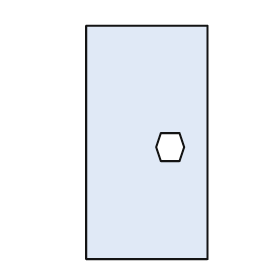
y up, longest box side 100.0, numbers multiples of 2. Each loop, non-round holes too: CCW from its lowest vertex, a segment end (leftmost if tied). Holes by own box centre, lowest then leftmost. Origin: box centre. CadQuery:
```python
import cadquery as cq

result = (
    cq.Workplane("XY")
    .moveTo(-26.0, -50.0)
    .lineTo(26.0, -50.0)
    .lineTo(26.0, 50.0)
    .lineTo(-26.0, 50.0)
    .close()
    .moveTo(6.0, -8.0)
    .lineTo(14.0, -8.0)
    .lineTo(16.0, -2.0)
    .lineTo(14.0, 4.0)
    .lineTo(6.0, 4.0)
    .lineTo(4.0, -2.0)
    .close()
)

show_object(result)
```